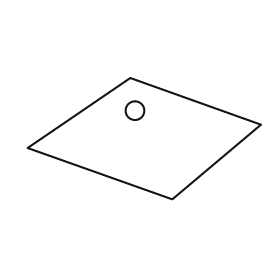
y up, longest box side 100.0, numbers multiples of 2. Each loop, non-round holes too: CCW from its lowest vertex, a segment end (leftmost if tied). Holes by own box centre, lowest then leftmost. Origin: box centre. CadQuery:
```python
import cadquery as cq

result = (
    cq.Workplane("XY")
    .moveTo(12.0, -26.0)
    .lineTo(50.0, 6.0)
    .lineTo(-6.0, 26.0)
    .lineTo(-50.0, -4.0)
    .close()
    .moveTo(-4.0, 12.0)
    .circle(4.0)
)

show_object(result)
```